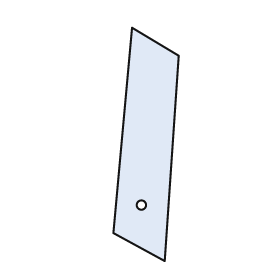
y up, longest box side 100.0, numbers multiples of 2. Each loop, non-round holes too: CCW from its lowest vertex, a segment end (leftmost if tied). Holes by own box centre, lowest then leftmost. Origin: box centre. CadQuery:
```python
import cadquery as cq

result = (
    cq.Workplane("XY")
    .moveTo(8.0, -50.0)
    .lineTo(14.0, 38.0)
    .lineTo(-6.0, 50.0)
    .lineTo(-14.0, -38.0)
    .close()
    .moveTo(-2.0, -26.0)
    .circle(2.0)
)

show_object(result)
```